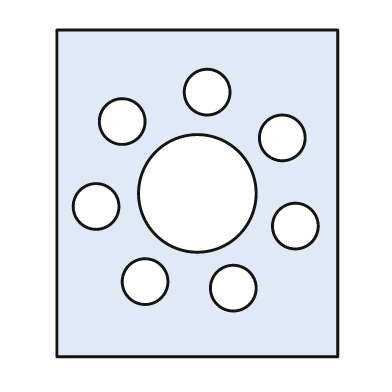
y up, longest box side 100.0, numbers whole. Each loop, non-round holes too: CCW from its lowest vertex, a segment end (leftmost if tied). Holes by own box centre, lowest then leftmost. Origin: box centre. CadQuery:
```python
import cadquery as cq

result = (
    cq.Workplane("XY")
    .moveTo(-43.0, -50.0)
    .lineTo(43.0, -50.0)
    .lineTo(43.0, 50.0)
    .lineTo(-43.0, 50.0)
    .close()
    .moveTo(11.0, -29.0)
    .circle(7.0)
    .moveTo(-16.0, -27.0)
    .circle(7.0)
    .moveTo(30.0, -10.0)
    .circle(7.0)
    .moveTo(-31.0, -4.0)
    .circle(7.0)
    .moveTo(0.0, 0.0)
    .circle(18.0)
    .moveTo(26.0, 17.0)
    .circle(7.0)
    .moveTo(-23.0, 22.0)
    .circle(7.0)
    .moveTo(3.0, 31.0)
    .circle(7.0)
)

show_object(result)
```